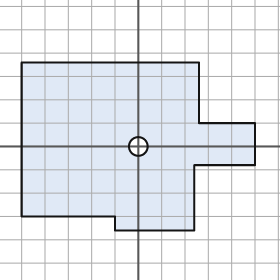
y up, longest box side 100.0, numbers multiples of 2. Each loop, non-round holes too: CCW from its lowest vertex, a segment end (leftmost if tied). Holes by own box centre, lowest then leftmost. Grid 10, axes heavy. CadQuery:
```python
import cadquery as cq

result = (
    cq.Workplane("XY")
    .moveTo(-10.0, -36.0)
    .lineTo(24.0, -36.0)
    .lineTo(24.0, -8.0)
    .lineTo(50.0, -8.0)
    .lineTo(50.0, 10.0)
    .lineTo(26.0, 10.0)
    .lineTo(26.0, 36.0)
    .lineTo(-50.0, 36.0)
    .lineTo(-50.0, -30.0)
    .lineTo(-10.0, -30.0)
    .close()
    .moveTo(0.0, 0.0)
    .circle(4.0)
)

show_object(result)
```